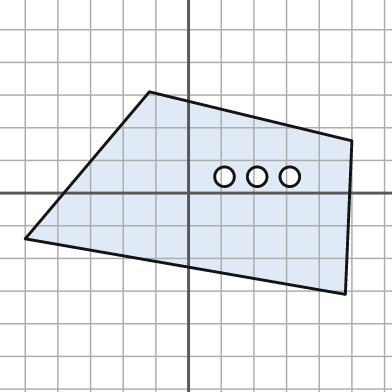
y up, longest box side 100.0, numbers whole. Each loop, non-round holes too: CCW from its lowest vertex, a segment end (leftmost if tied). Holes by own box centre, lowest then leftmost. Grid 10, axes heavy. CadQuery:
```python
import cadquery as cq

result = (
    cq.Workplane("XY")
    .moveTo(48.0, -31.0)
    .lineTo(50.0, 16.0)
    .lineTo(-12.0, 31.0)
    .lineTo(-50.0, -14.0)
    .close()
    .moveTo(11.0, 5.0)
    .circle(3.0)
    .moveTo(21.0, 5.0)
    .circle(3.0)
    .moveTo(31.0, 5.0)
    .circle(3.0)
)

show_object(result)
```